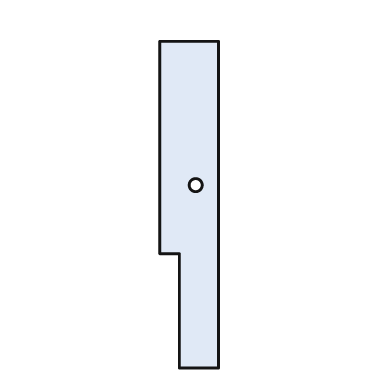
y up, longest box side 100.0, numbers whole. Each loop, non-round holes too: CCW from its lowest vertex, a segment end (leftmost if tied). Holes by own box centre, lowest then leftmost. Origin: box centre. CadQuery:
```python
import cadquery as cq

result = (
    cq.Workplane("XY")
    .moveTo(-3.0, -50.0)
    .lineTo(9.0, -50.0)
    .lineTo(9.0, 50.0)
    .lineTo(-9.0, 50.0)
    .lineTo(-9.0, -15.0)
    .lineTo(-3.0, -15.0)
    .close()
    .moveTo(2.0, 6.0)
    .circle(2.0)
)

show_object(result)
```